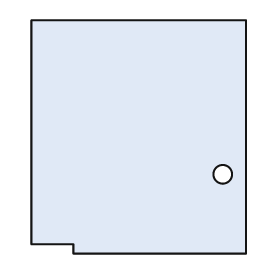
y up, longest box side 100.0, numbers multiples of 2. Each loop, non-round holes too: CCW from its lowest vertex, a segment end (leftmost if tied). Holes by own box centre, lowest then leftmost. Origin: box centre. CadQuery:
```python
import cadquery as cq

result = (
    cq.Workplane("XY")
    .moveTo(-28.0, -50.0)
    .lineTo(46.0, -50.0)
    .lineTo(46.0, 50.0)
    .lineTo(-46.0, 50.0)
    .lineTo(-46.0, -46.0)
    .lineTo(-28.0, -46.0)
    .close()
    .moveTo(36.0, -16.0)
    .circle(4.0)
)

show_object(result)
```